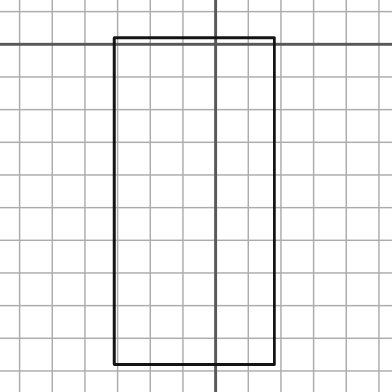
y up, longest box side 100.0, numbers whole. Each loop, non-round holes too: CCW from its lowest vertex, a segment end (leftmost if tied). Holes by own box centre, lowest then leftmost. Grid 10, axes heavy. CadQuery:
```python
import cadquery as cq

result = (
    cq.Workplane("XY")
    .moveTo(-31.0, -98.0)
    .lineTo(18.0, -98.0)
    .lineTo(18.0, 2.0)
    .lineTo(-31.0, 2.0)
    .close()
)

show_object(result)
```